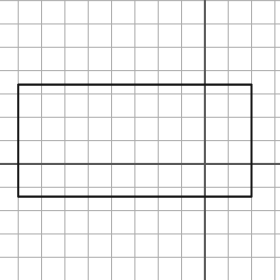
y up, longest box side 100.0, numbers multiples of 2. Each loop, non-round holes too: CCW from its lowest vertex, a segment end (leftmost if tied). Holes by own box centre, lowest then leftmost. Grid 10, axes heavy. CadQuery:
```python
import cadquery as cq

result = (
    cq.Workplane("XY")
    .moveTo(-80.0, -14.0)
    .lineTo(20.0, -14.0)
    .lineTo(20.0, 34.0)
    .lineTo(-80.0, 34.0)
    .close()
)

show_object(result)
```